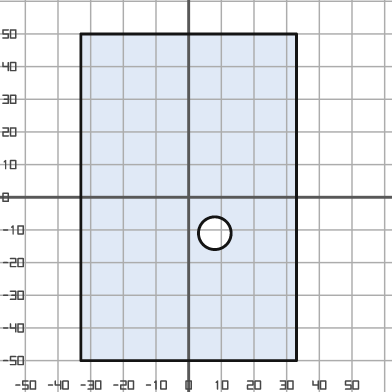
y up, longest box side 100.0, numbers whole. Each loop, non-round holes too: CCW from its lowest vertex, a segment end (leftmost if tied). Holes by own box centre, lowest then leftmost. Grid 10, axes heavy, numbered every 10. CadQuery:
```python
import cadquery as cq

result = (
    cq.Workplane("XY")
    .moveTo(-33.0, -50.0)
    .lineTo(33.0, -50.0)
    .lineTo(33.0, 50.0)
    .lineTo(-33.0, 50.0)
    .close()
    .moveTo(8.0, -11.0)
    .circle(5.0)
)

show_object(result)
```